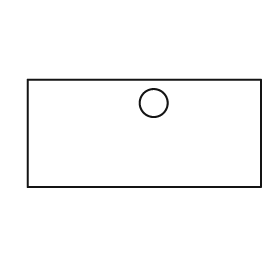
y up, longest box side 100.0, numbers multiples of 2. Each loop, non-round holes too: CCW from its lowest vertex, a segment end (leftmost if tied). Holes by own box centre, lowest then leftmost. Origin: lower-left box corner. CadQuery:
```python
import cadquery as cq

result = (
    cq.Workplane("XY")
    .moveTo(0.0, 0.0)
    .lineTo(100.0, 0.0)
    .lineTo(100.0, 46.0)
    .lineTo(0.0, 46.0)
    .close()
    .moveTo(54.0, 36.0)
    .circle(6.0)
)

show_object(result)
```